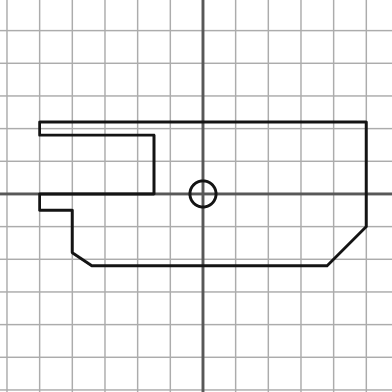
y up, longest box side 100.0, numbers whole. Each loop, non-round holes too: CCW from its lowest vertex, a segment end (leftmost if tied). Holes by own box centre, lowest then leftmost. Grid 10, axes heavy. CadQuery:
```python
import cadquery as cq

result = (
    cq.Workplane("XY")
    .moveTo(-34.0, -22.0)
    .lineTo(38.0, -22.0)
    .lineTo(50.0, -10.0)
    .lineTo(50.0, 22.0)
    .lineTo(-50.0, 22.0)
    .lineTo(-50.0, 18.0)
    .lineTo(-15.0, 18.0)
    .lineTo(-15.0, 0.0)
    .lineTo(-50.0, 0.0)
    .lineTo(-50.0, -5.0)
    .lineTo(-40.0, -5.0)
    .lineTo(-40.0, -18.0)
    .close()
    .moveTo(0.0, 0.0)
    .circle(4.0)
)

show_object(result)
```